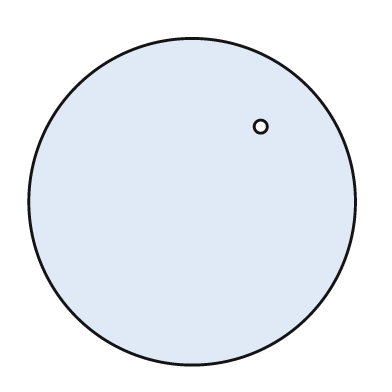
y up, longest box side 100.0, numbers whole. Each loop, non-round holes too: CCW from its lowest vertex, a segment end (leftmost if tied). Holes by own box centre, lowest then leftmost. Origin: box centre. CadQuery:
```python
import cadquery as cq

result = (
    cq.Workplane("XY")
    .moveTo(0.0, 0.0)
    .circle(50.0)
    .moveTo(21.0, 23.0)
    .circle(2.0)
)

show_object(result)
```